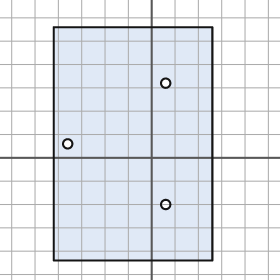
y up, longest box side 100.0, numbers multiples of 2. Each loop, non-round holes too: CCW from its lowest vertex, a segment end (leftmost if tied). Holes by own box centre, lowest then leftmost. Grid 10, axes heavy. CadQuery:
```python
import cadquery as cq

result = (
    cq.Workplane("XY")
    .moveTo(-42.0, -44.0)
    .lineTo(26.0, -44.0)
    .lineTo(26.0, 56.0)
    .lineTo(-42.0, 56.0)
    .close()
    .moveTo(6.0, -20.0)
    .circle(2.0)
    .moveTo(-36.0, 6.0)
    .circle(2.0)
    .moveTo(6.0, 32.0)
    .circle(2.0)
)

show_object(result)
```